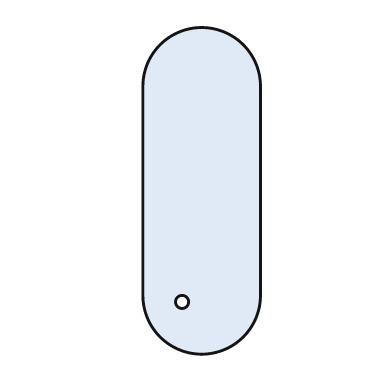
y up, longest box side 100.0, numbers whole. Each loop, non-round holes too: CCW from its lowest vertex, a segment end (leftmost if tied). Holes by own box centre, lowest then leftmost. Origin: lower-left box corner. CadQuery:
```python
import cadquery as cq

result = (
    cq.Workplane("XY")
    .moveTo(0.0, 18.0)
    .threePointArc((18.0, 0.0), (36.0, 18.0))
    .lineTo(36.0, 82.0)
    .threePointArc((18.0, 100.0), (0.0, 82.0))
    .close()
    .moveTo(12.0, 16.0)
    .circle(2.0)
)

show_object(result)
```